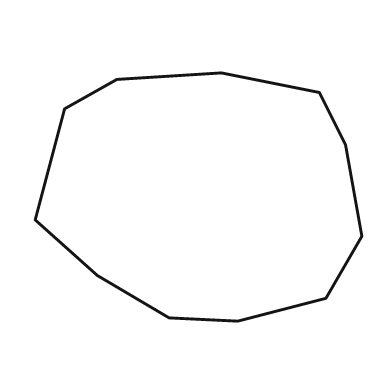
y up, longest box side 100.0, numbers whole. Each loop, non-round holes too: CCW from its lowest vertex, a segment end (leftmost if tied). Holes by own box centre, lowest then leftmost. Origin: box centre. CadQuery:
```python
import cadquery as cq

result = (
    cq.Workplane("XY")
    .moveTo(12.0, -38.0)
    .lineTo(39.0, -31.0)
    .lineTo(50.0, -12.0)
    .lineTo(45.0, 16.0)
    .lineTo(37.0, 32.0)
    .lineTo(7.0, 38.0)
    .lineTo(-25.0, 36.0)
    .lineTo(-41.0, 27.0)
    .lineTo(-50.0, -7.0)
    .lineTo(-31.0, -24.0)
    .lineTo(-9.0, -37.0)
    .close()
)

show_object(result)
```